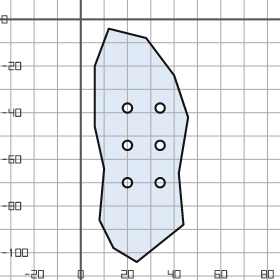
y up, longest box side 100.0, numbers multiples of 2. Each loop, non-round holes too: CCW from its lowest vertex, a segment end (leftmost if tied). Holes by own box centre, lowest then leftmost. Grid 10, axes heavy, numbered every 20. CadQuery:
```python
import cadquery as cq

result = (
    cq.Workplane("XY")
    .moveTo(24.0, -104.0)
    .lineTo(44.0, -88.0)
    .lineTo(42.0, -66.0)
    .lineTo(46.0, -42.0)
    .lineTo(40.0, -24.0)
    .lineTo(28.0, -8.0)
    .lineTo(12.0, -4.0)
    .lineTo(6.0, -20.0)
    .lineTo(6.0, -46.0)
    .lineTo(10.0, -64.0)
    .lineTo(8.0, -86.0)
    .lineTo(14.0, -98.0)
    .close()
    .moveTo(20.0, -70.0)
    .circle(2.0)
    .moveTo(34.0, -70.0)
    .circle(2.0)
    .moveTo(20.0, -54.0)
    .circle(2.0)
    .moveTo(34.0, -54.0)
    .circle(2.0)
    .moveTo(20.0, -38.0)
    .circle(2.0)
    .moveTo(34.0, -38.0)
    .circle(2.0)
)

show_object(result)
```